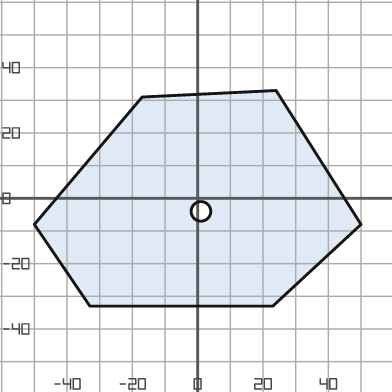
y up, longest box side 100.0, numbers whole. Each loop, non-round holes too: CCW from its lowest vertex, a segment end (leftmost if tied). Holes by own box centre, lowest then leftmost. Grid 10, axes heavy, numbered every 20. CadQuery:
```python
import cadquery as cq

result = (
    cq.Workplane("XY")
    .moveTo(-33.0, -33.0)
    .lineTo(23.0, -33.0)
    .lineTo(50.0, -8.0)
    .lineTo(24.0, 33.0)
    .lineTo(-17.0, 31.0)
    .lineTo(-50.0, -8.0)
    .close()
    .moveTo(1.0, -4.0)
    .circle(3.0)
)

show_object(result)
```